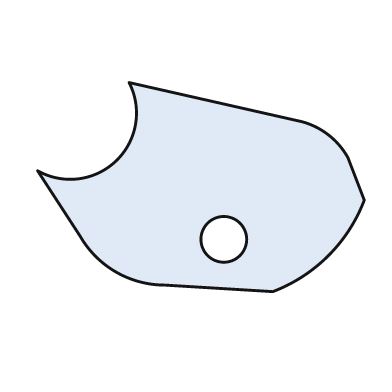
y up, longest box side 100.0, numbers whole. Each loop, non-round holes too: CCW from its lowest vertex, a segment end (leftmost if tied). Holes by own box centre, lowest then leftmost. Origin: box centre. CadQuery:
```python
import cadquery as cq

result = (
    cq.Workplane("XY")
    .moveTo(22.0, -32.0)
    .threePointArc((39.0, -21.0), (50.0, -4.0))
    .lineTo(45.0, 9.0)
    .threePointArc((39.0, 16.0), (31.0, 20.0))
    .lineTo(-22.0, 32.0)
    .threePointArc((-26.0, 8.0), (-50.0, 5.0))
    .lineTo(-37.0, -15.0)
    .threePointArc((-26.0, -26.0), (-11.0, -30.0))
    .close()
    .moveTo(7.0, -16.0)
    .circle(7.0)
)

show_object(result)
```